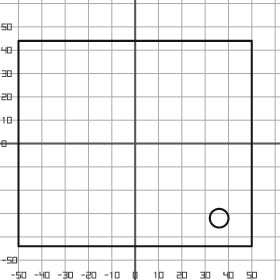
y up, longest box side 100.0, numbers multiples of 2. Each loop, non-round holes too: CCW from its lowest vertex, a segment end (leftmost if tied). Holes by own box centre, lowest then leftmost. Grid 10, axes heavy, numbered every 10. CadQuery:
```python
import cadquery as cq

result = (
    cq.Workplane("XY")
    .moveTo(-50.0, -44.0)
    .lineTo(50.0, -44.0)
    .lineTo(50.0, 44.0)
    .lineTo(-50.0, 44.0)
    .close()
    .moveTo(36.0, -32.0)
    .circle(4.0)
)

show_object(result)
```